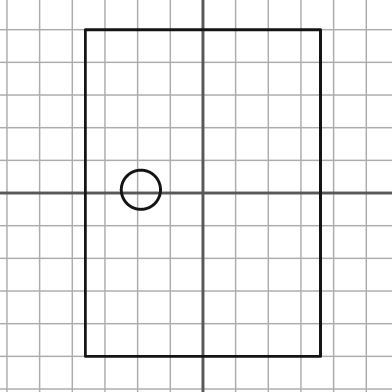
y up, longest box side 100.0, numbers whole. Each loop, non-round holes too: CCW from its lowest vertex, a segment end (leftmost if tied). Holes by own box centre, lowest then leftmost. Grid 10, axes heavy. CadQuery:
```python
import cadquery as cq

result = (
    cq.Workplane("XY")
    .moveTo(-36.0, -50.0)
    .lineTo(36.0, -50.0)
    .lineTo(36.0, 50.0)
    .lineTo(-36.0, 50.0)
    .close()
    .moveTo(-19.0, 1.0)
    .circle(6.0)
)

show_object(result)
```